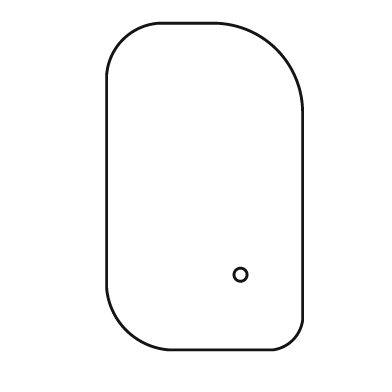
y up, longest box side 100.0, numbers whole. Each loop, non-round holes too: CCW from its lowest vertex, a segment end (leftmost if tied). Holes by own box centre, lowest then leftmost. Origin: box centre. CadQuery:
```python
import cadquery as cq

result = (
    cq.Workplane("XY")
    .moveTo(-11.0, -50.0)
    .lineTo(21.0, -50.0)
    .threePointArc((27.0, -47.0), (30.0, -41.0))
    .lineTo(30.0, 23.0)
    .threePointArc((22.0, 42.0), (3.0, 50.0))
    .lineTo(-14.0, 50.0)
    .threePointArc((-25.0, 45.0), (-30.0, 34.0))
    .lineTo(-30.0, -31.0)
    .threePointArc((-24.0, -44.0), (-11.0, -50.0))
    .close()
    .moveTo(11.0, -27.0)
    .circle(2.0)
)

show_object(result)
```